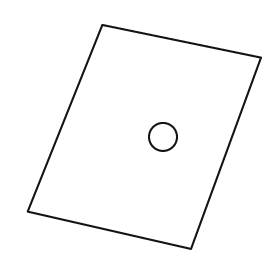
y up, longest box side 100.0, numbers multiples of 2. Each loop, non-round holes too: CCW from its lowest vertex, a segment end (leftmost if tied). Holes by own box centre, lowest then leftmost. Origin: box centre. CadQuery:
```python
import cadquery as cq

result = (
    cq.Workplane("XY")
    .moveTo(20.0, -48.0)
    .lineTo(50.0, 34.0)
    .lineTo(-18.0, 48.0)
    .lineTo(-50.0, -32.0)
    .close()
    .moveTo(8.0, 0.0)
    .circle(6.0)
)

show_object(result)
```